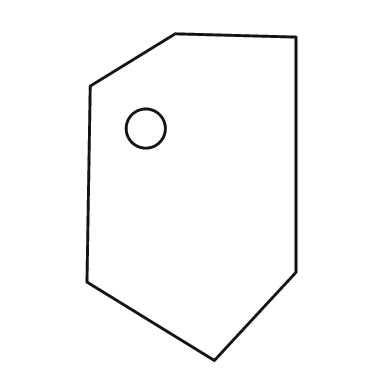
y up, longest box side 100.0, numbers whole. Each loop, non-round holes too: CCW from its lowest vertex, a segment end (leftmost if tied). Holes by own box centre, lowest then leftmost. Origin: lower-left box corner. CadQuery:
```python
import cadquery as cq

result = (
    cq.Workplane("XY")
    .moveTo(39.0, 0.0)
    .lineTo(64.0, 27.0)
    .lineTo(64.0, 99.0)
    .lineTo(27.0, 100.0)
    .lineTo(1.0, 84.0)
    .lineTo(0.0, 24.0)
    .close()
    .moveTo(18.0, 71.0)
    .circle(6.0)
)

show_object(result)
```